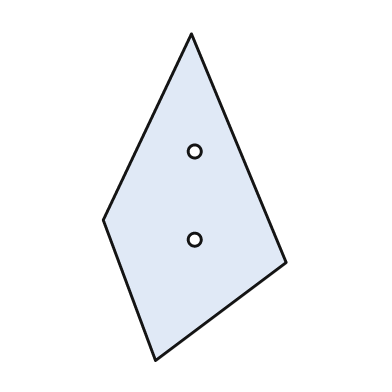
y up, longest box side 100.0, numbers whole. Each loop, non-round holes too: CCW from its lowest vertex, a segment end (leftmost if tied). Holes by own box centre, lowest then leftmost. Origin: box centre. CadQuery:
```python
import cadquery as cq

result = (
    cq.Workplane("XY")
    .moveTo(-12.0, -50.0)
    .lineTo(28.0, -20.0)
    .lineTo(-1.0, 50.0)
    .lineTo(-28.0, -7.0)
    .close()
    .moveTo(0.0, -13.0)
    .circle(2.0)
    .moveTo(0.0, 14.0)
    .circle(2.0)
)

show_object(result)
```